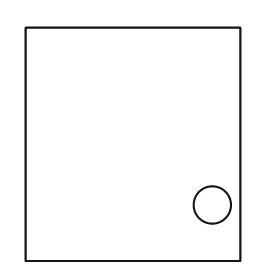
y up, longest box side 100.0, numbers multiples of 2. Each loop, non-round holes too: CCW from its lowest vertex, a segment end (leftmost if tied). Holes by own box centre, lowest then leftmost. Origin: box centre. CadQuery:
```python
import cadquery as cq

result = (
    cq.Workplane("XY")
    .moveTo(-46.0, -50.0)
    .lineTo(46.0, -50.0)
    .lineTo(46.0, 50.0)
    .lineTo(-46.0, 50.0)
    .close()
    .moveTo(34.0, -26.0)
    .circle(8.0)
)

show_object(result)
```